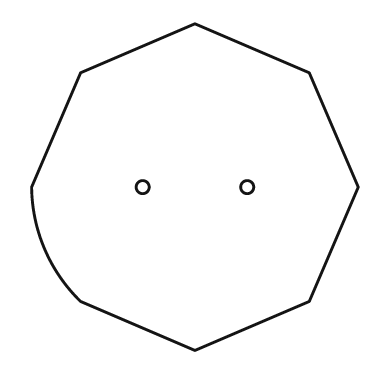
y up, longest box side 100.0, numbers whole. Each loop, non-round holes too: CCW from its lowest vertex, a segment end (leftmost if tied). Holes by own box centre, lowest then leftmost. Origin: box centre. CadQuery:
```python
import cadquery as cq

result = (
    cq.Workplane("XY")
    .moveTo(0.0, -50.0)
    .lineTo(35.0, -35.0)
    .lineTo(50.0, 0.0)
    .lineTo(35.0, 35.0)
    .lineTo(0.0, 50.0)
    .lineTo(-35.0, 35.0)
    .lineTo(-50.0, 0.0)
    .threePointArc((-46.0, -19.0), (-35.0, -35.0))
    .close()
    .moveTo(-16.0, 0.0)
    .circle(2.0)
    .moveTo(16.0, 0.0)
    .circle(2.0)
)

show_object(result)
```